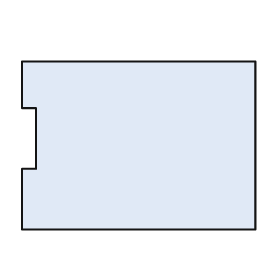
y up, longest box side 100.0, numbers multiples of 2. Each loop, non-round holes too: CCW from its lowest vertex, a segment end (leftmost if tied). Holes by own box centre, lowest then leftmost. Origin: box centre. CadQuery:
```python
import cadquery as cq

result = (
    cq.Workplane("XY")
    .moveTo(-50.0, -36.0)
    .lineTo(50.0, -36.0)
    .lineTo(50.0, 36.0)
    .lineTo(-50.0, 36.0)
    .lineTo(-50.0, 16.0)
    .lineTo(-44.0, 16.0)
    .lineTo(-44.0, -10.0)
    .lineTo(-50.0, -10.0)
    .close()
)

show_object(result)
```